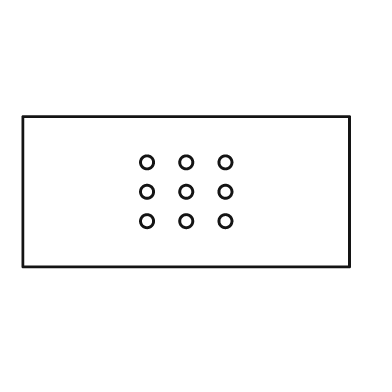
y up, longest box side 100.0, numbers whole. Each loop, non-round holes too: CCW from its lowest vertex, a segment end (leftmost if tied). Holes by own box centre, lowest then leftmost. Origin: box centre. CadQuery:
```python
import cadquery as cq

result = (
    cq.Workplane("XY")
    .moveTo(-50.0, -23.0)
    .lineTo(50.0, -23.0)
    .lineTo(50.0, 23.0)
    .lineTo(-50.0, 23.0)
    .close()
    .moveTo(-12.0, -9.0)
    .circle(2.0)
    .moveTo(0.0, -9.0)
    .circle(2.0)
    .moveTo(12.0, -9.0)
    .circle(2.0)
    .moveTo(-12.0, 0.0)
    .circle(2.0)
    .moveTo(0.0, 0.0)
    .circle(2.0)
    .moveTo(12.0, 0.0)
    .circle(2.0)
    .moveTo(-12.0, 9.0)
    .circle(2.0)
    .moveTo(0.0, 9.0)
    .circle(2.0)
    .moveTo(12.0, 9.0)
    .circle(2.0)
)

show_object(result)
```